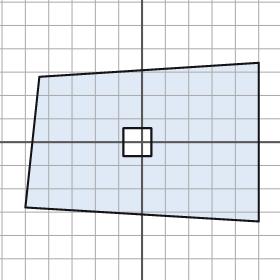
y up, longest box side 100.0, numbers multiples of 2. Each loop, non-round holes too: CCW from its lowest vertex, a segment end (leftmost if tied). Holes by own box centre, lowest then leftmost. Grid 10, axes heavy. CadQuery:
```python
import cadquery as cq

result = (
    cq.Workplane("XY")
    .moveTo(50.0, -34.0)
    .lineTo(50.0, 34.0)
    .lineTo(-44.0, 28.0)
    .lineTo(-50.0, -28.0)
    .close()
    .moveTo(-8.0, -6.0)
    .lineTo(4.0, -6.0)
    .lineTo(4.0, 6.0)
    .lineTo(-8.0, 6.0)
    .close()
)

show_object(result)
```